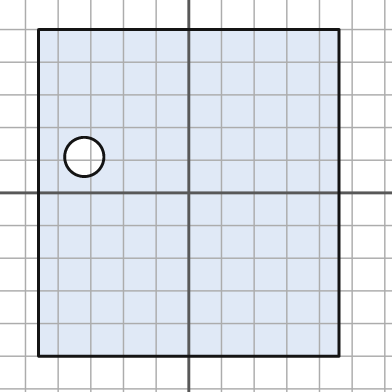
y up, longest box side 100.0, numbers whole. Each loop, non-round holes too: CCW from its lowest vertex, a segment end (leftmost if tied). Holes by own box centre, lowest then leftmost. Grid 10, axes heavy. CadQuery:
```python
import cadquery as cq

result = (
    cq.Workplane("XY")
    .moveTo(-46.0, -50.0)
    .lineTo(46.0, -50.0)
    .lineTo(46.0, 50.0)
    .lineTo(-46.0, 50.0)
    .close()
    .moveTo(-32.0, 11.0)
    .circle(6.0)
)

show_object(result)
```